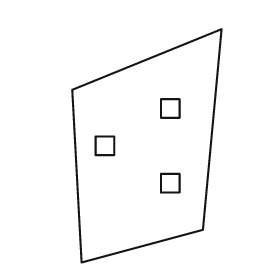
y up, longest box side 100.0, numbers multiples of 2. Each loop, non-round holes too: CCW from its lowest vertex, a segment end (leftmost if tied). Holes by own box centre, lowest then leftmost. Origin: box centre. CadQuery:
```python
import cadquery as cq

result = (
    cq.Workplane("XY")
    .moveTo(-28.0, -50.0)
    .lineTo(24.0, -36.0)
    .lineTo(32.0, 50.0)
    .lineTo(-32.0, 24.0)
    .close()
    .moveTo(6.0, -20.0)
    .lineTo(14.0, -20.0)
    .lineTo(14.0, -12.0)
    .lineTo(6.0, -12.0)
    .close()
    .moveTo(-22.0, -4.0)
    .lineTo(-14.0, -4.0)
    .lineTo(-14.0, 4.0)
    .lineTo(-22.0, 4.0)
    .close()
    .moveTo(6.0, 12.0)
    .lineTo(14.0, 12.0)
    .lineTo(14.0, 20.0)
    .lineTo(6.0, 20.0)
    .close()
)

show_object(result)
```